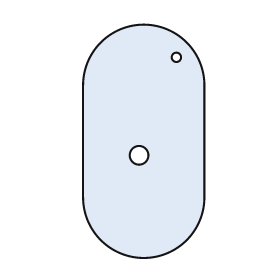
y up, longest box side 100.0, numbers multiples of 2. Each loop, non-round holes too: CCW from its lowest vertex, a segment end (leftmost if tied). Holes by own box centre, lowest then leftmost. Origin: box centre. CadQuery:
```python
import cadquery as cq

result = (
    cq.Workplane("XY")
    .moveTo(-26.0, -24.0)
    .threePointArc((0.0, -50.0), (26.0, -24.0))
    .lineTo(26.0, 24.0)
    .threePointArc((0.0, 50.0), (-26.0, 24.0))
    .close()
    .moveTo(-2.0, -6.0)
    .circle(4.0)
    .moveTo(14.0, 36.0)
    .circle(2.0)
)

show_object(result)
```